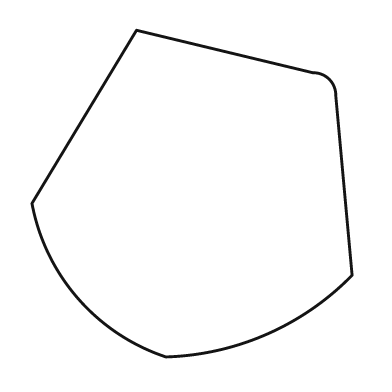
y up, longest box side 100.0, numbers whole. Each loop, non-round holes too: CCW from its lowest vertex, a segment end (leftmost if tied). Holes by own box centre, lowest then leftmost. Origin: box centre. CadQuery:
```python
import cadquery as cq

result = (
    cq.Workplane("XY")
    .moveTo(-8.0, -50.0)
    .threePointArc((23.0, -43.0), (49.0, -25.0))
    .lineTo(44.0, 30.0)
    .threePointArc((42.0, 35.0), (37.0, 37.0))
    .lineTo(-17.0, 50.0)
    .lineTo(-49.0, -3.0)
    .threePointArc((-35.0, -32.0), (-8.0, -50.0))
    .close()
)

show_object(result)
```